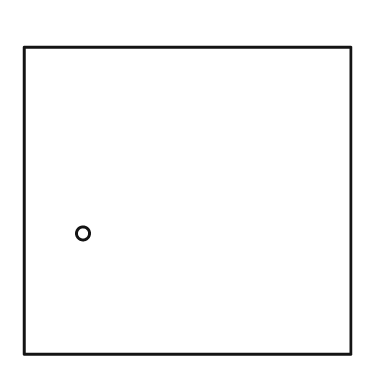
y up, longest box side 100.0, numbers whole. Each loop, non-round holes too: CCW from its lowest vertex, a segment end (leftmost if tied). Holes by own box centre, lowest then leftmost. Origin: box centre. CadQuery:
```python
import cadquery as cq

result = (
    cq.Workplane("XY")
    .moveTo(-50.0, -47.0)
    .lineTo(50.0, -47.0)
    .lineTo(50.0, 47.0)
    .lineTo(-50.0, 47.0)
    .close()
    .moveTo(-32.0, -10.0)
    .circle(2.0)
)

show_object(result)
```